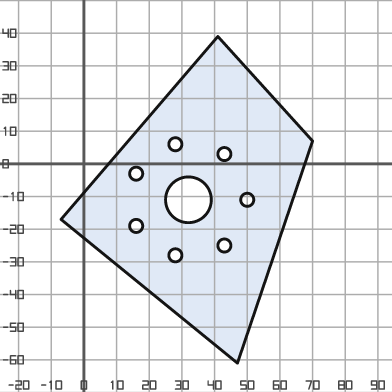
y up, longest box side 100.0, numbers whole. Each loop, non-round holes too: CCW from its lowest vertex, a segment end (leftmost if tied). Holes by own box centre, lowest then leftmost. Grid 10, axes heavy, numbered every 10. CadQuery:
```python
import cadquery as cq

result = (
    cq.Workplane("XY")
    .moveTo(47.0, -61.0)
    .lineTo(70.0, 7.0)
    .lineTo(41.0, 39.0)
    .lineTo(-7.0, -17.0)
    .close()
    .moveTo(28.0, -28.0)
    .circle(2.0)
    .moveTo(43.0, -25.0)
    .circle(2.0)
    .moveTo(16.0, -19.0)
    .circle(2.0)
    .moveTo(32.0, -11.0)
    .circle(7.0)
    .moveTo(50.0, -11.0)
    .circle(2.0)
    .moveTo(16.0, -3.0)
    .circle(2.0)
    .moveTo(43.0, 3.0)
    .circle(2.0)
    .moveTo(28.0, 6.0)
    .circle(2.0)
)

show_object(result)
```